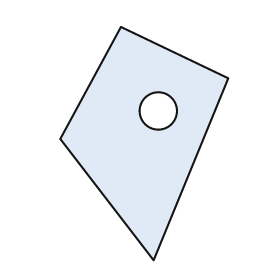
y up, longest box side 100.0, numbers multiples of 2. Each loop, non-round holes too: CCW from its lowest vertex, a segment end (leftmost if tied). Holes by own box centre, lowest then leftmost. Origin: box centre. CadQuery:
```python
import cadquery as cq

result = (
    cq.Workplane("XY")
    .moveTo(4.0, -50.0)
    .lineTo(36.0, 28.0)
    .lineTo(-10.0, 50.0)
    .lineTo(-36.0, 2.0)
    .close()
    .moveTo(6.0, 14.0)
    .circle(8.0)
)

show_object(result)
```